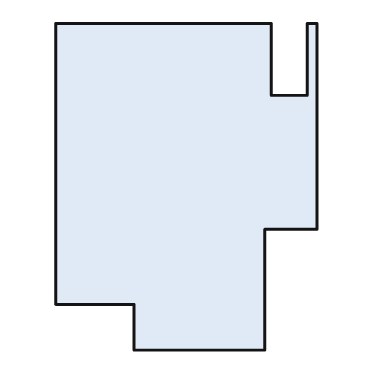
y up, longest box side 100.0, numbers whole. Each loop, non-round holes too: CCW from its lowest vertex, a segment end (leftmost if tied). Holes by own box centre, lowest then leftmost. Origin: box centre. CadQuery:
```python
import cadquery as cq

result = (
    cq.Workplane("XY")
    .moveTo(-16.0, -50.0)
    .lineTo(24.0, -50.0)
    .lineTo(24.0, -13.0)
    .lineTo(40.0, -13.0)
    .lineTo(40.0, 50.0)
    .lineTo(37.0, 50.0)
    .lineTo(37.0, 28.0)
    .lineTo(26.0, 28.0)
    .lineTo(26.0, 50.0)
    .lineTo(-40.0, 50.0)
    .lineTo(-40.0, -36.0)
    .lineTo(-16.0, -36.0)
    .close()
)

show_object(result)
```